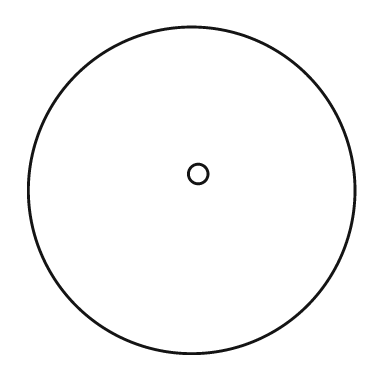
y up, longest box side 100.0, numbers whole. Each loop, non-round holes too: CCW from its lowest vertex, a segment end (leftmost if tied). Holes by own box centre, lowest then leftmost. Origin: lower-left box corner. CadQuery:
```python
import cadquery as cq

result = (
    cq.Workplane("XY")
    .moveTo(50.0, 50.0)
    .circle(50.0)
    .moveTo(52.0, 55.0)
    .circle(3.0)
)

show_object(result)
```